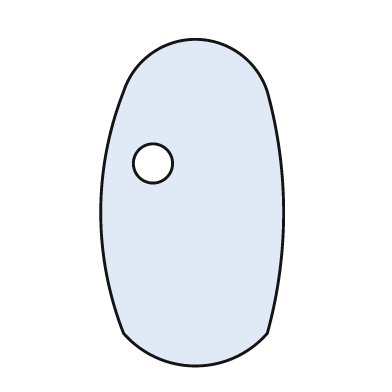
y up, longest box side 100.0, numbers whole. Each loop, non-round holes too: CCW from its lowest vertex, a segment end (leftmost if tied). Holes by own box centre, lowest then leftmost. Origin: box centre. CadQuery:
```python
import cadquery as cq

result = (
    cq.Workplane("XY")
    .moveTo(-21.0, -40.0)
    .threePointArc((1.0, -50.0), (23.0, -40.0))
    .threePointArc((28.0, -3.0), (23.0, 34.0))
    .threePointArc((1.0, 50.0), (-21.0, 34.0))
    .threePointArc((-28.0, -3.0), (-21.0, -40.0))
    .close()
    .moveTo(-12.0, 12.0)
    .circle(6.0)
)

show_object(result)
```